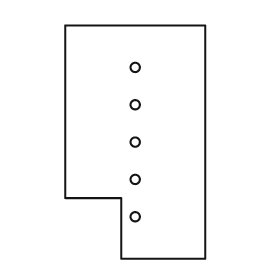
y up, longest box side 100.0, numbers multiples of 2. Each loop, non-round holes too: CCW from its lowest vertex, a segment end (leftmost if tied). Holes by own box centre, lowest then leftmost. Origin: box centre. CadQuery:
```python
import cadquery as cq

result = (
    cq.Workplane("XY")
    .moveTo(-6.0, -50.0)
    .lineTo(30.0, -50.0)
    .lineTo(30.0, 50.0)
    .lineTo(-30.0, 50.0)
    .lineTo(-30.0, -24.0)
    .lineTo(-6.0, -24.0)
    .close()
    .moveTo(0.0, -32.0)
    .circle(2.0)
    .moveTo(0.0, -16.0)
    .circle(2.0)
    .moveTo(0.0, 0.0)
    .circle(2.0)
    .moveTo(0.0, 16.0)
    .circle(2.0)
    .moveTo(0.0, 32.0)
    .circle(2.0)
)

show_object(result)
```